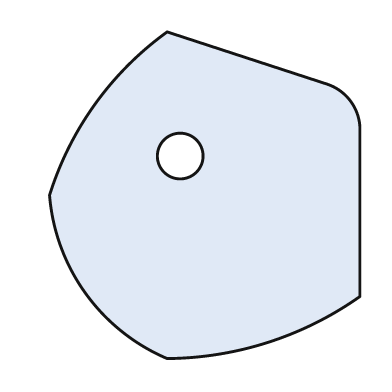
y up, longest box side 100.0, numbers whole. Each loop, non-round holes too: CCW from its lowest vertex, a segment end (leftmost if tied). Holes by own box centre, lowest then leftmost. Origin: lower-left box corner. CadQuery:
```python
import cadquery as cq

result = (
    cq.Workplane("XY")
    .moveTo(36.0, 0.0)
    .threePointArc((67.0, 5.0), (95.0, 19.0))
    .lineTo(95.0, 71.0)
    .threePointArc((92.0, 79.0), (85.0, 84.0))
    .lineTo(36.0, 100.0)
    .threePointArc((14.0, 78.0), (0.0, 50.0))
    .threePointArc((11.0, 20.0), (36.0, 0.0))
    .close()
    .moveTo(40.0, 62.0)
    .circle(7.0)
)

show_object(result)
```